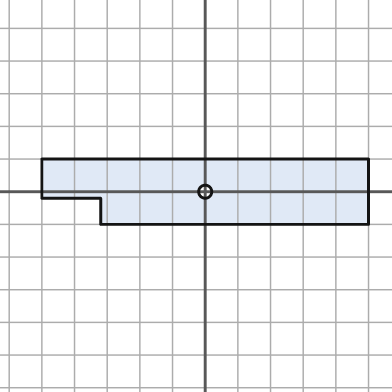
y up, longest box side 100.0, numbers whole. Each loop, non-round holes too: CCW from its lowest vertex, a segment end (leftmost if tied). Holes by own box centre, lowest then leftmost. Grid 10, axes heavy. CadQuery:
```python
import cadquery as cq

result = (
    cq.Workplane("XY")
    .moveTo(-32.0, -10.0)
    .lineTo(50.0, -10.0)
    .lineTo(50.0, 10.0)
    .lineTo(-50.0, 10.0)
    .lineTo(-50.0, -2.0)
    .lineTo(-32.0, -2.0)
    .close()
    .moveTo(0.0, 0.0)
    .circle(2.0)
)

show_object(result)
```